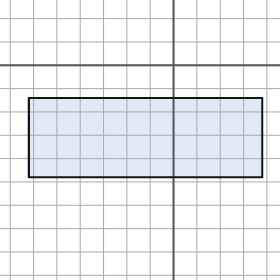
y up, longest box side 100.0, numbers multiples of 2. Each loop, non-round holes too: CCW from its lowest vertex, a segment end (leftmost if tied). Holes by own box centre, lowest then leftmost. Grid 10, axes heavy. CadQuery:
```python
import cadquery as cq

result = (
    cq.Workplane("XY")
    .moveTo(-62.0, -48.0)
    .lineTo(38.0, -48.0)
    .lineTo(38.0, -14.0)
    .lineTo(-62.0, -14.0)
    .close()
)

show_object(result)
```